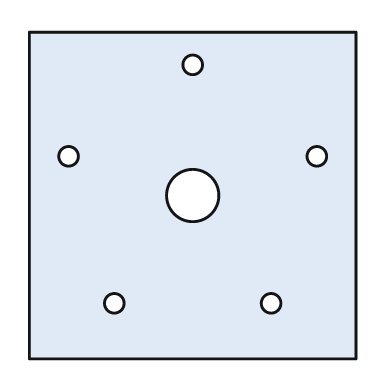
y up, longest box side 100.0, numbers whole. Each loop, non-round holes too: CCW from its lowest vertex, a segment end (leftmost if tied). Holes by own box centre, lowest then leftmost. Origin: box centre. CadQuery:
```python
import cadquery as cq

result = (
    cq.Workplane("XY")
    .moveTo(-50.0, -50.0)
    .lineTo(50.0, -50.0)
    .lineTo(50.0, 50.0)
    .lineTo(-50.0, 50.0)
    .close()
    .moveTo(-24.0, -33.0)
    .circle(3.0)
    .moveTo(24.0, -33.0)
    .circle(3.0)
    .moveTo(0.0, 0.0)
    .circle(8.0)
    .moveTo(-38.0, 12.0)
    .circle(3.0)
    .moveTo(38.0, 12.0)
    .circle(3.0)
    .moveTo(0.0, 40.0)
    .circle(3.0)
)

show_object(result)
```